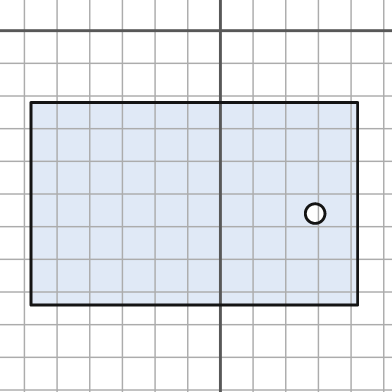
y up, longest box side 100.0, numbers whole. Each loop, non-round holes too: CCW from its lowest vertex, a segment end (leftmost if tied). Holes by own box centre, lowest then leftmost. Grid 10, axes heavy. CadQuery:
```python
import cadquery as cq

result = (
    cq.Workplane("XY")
    .moveTo(-58.0, -84.0)
    .lineTo(42.0, -84.0)
    .lineTo(42.0, -22.0)
    .lineTo(-58.0, -22.0)
    .close()
    .moveTo(29.0, -56.0)
    .circle(3.0)
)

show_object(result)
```